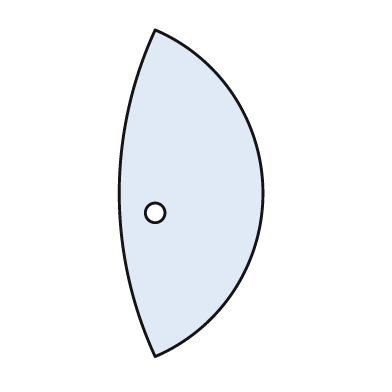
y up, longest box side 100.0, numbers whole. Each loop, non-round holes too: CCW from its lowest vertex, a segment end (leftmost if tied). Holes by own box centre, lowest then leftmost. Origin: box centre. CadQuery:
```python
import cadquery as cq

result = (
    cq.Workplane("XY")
    .moveTo(-11.0, -50.0)
    .threePointArc((22.0, 0.0), (-11.0, 50.0))
    .threePointArc((-22.0, 0.0), (-11.0, -50.0))
    .close()
    .moveTo(-11.0, -6.0)
    .circle(3.0)
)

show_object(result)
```